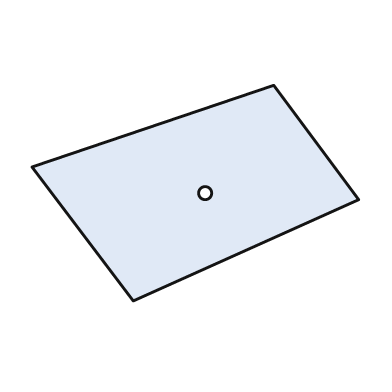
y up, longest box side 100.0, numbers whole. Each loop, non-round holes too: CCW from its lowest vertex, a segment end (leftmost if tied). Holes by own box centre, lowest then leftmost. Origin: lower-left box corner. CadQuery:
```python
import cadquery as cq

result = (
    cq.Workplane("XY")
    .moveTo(31.0, 0.0)
    .lineTo(100.0, 31.0)
    .lineTo(74.0, 66.0)
    .lineTo(0.0, 41.0)
    .close()
    .moveTo(53.0, 33.0)
    .circle(2.0)
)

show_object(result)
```